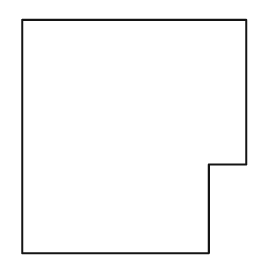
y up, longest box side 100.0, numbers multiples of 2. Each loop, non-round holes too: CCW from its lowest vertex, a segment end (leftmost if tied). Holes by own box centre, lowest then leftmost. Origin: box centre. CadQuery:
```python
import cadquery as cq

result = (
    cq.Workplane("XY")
    .moveTo(-48.0, -50.0)
    .lineTo(32.0, -50.0)
    .lineTo(32.0, -12.0)
    .lineTo(48.0, -12.0)
    .lineTo(48.0, 50.0)
    .lineTo(-48.0, 50.0)
    .close()
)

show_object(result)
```